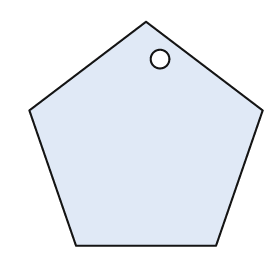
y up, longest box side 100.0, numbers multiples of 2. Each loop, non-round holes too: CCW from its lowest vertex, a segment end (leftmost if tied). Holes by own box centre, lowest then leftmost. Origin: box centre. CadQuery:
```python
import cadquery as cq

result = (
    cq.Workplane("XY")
    .moveTo(-30.0, -48.0)
    .lineTo(30.0, -48.0)
    .lineTo(50.0, 10.0)
    .lineTo(0.0, 48.0)
    .lineTo(-50.0, 10.0)
    .close()
    .moveTo(6.0, 32.0)
    .circle(4.0)
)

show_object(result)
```